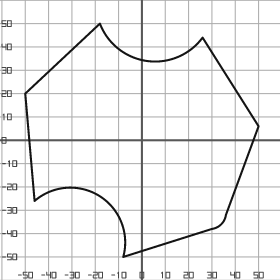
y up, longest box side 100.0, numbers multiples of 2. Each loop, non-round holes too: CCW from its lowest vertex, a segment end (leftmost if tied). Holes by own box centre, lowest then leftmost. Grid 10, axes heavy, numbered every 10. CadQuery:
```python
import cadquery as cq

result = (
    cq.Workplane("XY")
    .moveTo(-8.0, -50.0)
    .lineTo(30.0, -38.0)
    .threePointArc((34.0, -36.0), (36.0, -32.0))
    .lineTo(50.0, 6.0)
    .lineTo(26.0, 44.0)
    .threePointArc((2.0, 34.0), (-18.0, 50.0))
    .lineTo(-50.0, 20.0)
    .lineTo(-46.0, -26.0)
    .threePointArc((-18.0, -24.0), (-8.0, -50.0))
    .close()
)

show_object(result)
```